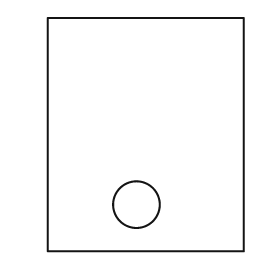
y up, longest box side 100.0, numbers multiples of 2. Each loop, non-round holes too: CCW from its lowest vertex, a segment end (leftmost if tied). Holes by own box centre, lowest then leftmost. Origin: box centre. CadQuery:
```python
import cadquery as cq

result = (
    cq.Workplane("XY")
    .moveTo(-42.0, -50.0)
    .lineTo(42.0, -50.0)
    .lineTo(42.0, 50.0)
    .lineTo(-42.0, 50.0)
    .close()
    .moveTo(-4.0, -30.0)
    .circle(10.0)
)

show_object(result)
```